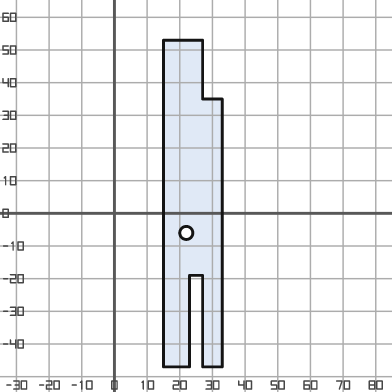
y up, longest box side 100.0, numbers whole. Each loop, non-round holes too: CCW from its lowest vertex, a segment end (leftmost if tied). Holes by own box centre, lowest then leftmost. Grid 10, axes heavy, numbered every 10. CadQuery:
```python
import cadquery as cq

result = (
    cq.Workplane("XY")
    .moveTo(15.0, -47.0)
    .lineTo(23.0, -47.0)
    .lineTo(23.0, -19.0)
    .lineTo(27.0, -19.0)
    .lineTo(27.0, -47.0)
    .lineTo(33.0, -47.0)
    .lineTo(33.0, 35.0)
    .lineTo(27.0, 35.0)
    .lineTo(27.0, 53.0)
    .lineTo(15.0, 53.0)
    .close()
    .moveTo(22.0, -6.0)
    .circle(2.0)
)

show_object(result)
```